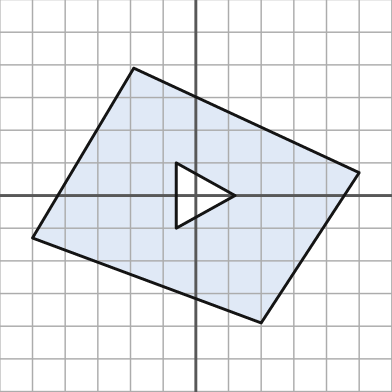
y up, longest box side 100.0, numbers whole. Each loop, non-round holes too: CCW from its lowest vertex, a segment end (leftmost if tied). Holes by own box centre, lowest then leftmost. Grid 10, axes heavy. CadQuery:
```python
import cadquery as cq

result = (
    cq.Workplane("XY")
    .moveTo(20.0, -39.0)
    .lineTo(50.0, 7.0)
    .lineTo(-19.0, 39.0)
    .lineTo(-50.0, -13.0)
    .close()
    .moveTo(-6.0, -10.0)
    .lineTo(12.0, 0.0)
    .lineTo(-6.0, 10.0)
    .close()
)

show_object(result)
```